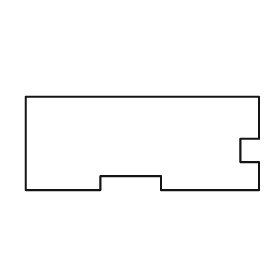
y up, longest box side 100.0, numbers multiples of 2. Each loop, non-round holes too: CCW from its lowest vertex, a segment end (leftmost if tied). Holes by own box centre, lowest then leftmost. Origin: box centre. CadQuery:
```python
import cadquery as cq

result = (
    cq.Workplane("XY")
    .moveTo(-50.0, -20.0)
    .lineTo(-18.0, -20.0)
    .lineTo(-18.0, -14.0)
    .lineTo(8.0, -14.0)
    .lineTo(8.0, -20.0)
    .lineTo(50.0, -20.0)
    .lineTo(50.0, -8.0)
    .lineTo(42.0, -8.0)
    .lineTo(42.0, 2.0)
    .lineTo(50.0, 2.0)
    .lineTo(50.0, 20.0)
    .lineTo(-50.0, 20.0)
    .close()
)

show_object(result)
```